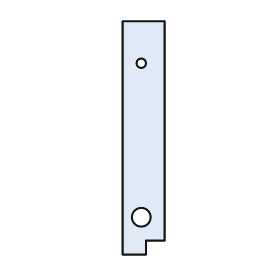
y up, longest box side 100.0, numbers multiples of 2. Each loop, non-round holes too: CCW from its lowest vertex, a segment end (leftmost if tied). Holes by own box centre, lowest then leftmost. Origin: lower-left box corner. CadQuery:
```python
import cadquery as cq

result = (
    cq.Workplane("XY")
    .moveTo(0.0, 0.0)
    .lineTo(10.0, 0.0)
    .lineTo(10.0, 6.0)
    .lineTo(18.0, 6.0)
    .lineTo(18.0, 100.0)
    .lineTo(0.0, 100.0)
    .close()
    .moveTo(8.0, 16.0)
    .circle(4.0)
    .moveTo(8.0, 82.0)
    .circle(2.0)
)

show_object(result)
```